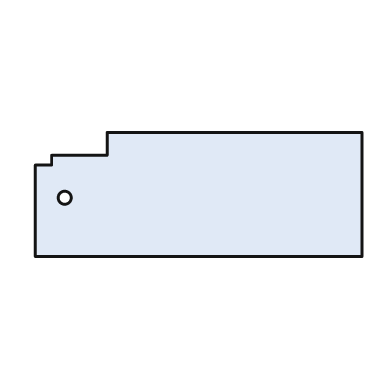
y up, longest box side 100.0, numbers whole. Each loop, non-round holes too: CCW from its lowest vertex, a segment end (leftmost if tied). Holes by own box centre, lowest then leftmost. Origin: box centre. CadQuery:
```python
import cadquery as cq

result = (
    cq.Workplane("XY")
    .moveTo(-50.0, -19.0)
    .lineTo(50.0, -19.0)
    .lineTo(50.0, 19.0)
    .lineTo(-28.0, 19.0)
    .lineTo(-28.0, 12.0)
    .lineTo(-45.0, 12.0)
    .lineTo(-45.0, 9.0)
    .lineTo(-50.0, 9.0)
    .close()
    .moveTo(-41.0, -1.0)
    .circle(2.0)
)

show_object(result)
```